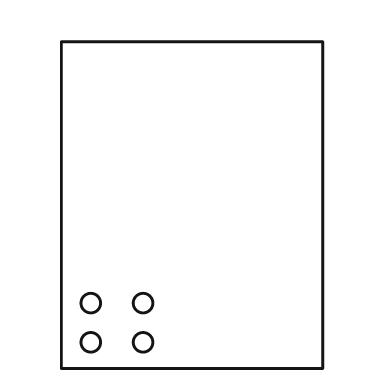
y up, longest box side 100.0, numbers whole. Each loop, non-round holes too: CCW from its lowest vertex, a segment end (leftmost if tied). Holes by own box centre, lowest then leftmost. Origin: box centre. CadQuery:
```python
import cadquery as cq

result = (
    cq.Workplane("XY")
    .moveTo(-40.0, -50.0)
    .lineTo(40.0, -50.0)
    .lineTo(40.0, 50.0)
    .lineTo(-40.0, 50.0)
    .close()
    .moveTo(-31.0, -42.0)
    .circle(3.0)
    .moveTo(-15.0, -42.0)
    .circle(3.0)
    .moveTo(-31.0, -30.0)
    .circle(3.0)
    .moveTo(-15.0, -30.0)
    .circle(3.0)
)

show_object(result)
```